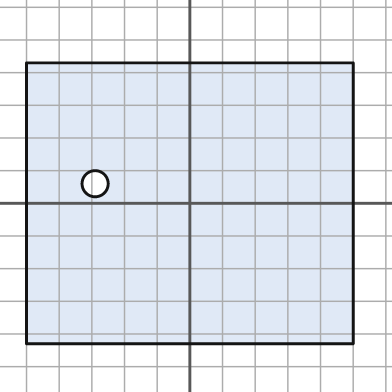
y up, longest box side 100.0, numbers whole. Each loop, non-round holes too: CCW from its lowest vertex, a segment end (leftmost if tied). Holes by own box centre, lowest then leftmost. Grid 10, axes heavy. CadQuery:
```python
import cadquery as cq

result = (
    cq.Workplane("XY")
    .moveTo(-50.0, -43.0)
    .lineTo(50.0, -43.0)
    .lineTo(50.0, 43.0)
    .lineTo(-50.0, 43.0)
    .close()
    .moveTo(-29.0, 6.0)
    .circle(4.0)
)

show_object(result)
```